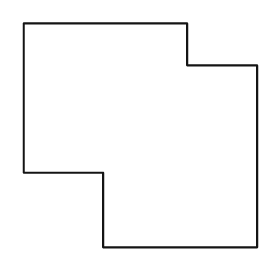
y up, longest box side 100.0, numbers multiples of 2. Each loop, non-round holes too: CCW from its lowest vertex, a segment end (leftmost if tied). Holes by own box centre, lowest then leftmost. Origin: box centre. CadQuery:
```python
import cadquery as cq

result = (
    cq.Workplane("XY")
    .moveTo(-16.0, -48.0)
    .lineTo(50.0, -48.0)
    .lineTo(50.0, 30.0)
    .lineTo(20.0, 30.0)
    .lineTo(20.0, 48.0)
    .lineTo(-50.0, 48.0)
    .lineTo(-50.0, -16.0)
    .lineTo(-16.0, -16.0)
    .close()
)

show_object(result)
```